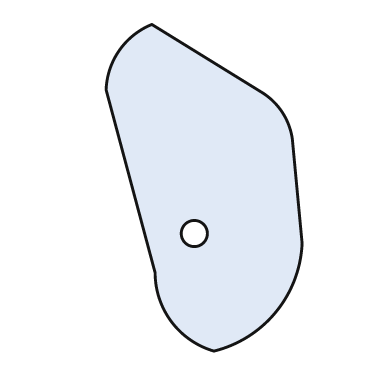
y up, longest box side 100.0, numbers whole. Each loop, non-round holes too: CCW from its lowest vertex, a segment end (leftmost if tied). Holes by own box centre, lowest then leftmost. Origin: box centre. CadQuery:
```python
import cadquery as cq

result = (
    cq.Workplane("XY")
    .moveTo(3.0, -50.0)
    .threePointArc((22.0, -38.0), (30.0, -17.0))
    .lineTo(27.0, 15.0)
    .threePointArc((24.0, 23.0), (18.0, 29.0))
    .lineTo(-16.0, 50.0)
    .threePointArc((-26.0, 42.0), (-30.0, 30.0))
    .lineTo(-15.0, -26.0)
    .threePointArc((-10.0, -41.0), (3.0, -50.0))
    .close()
    .moveTo(-3.0, -14.0)
    .circle(4.0)
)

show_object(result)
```